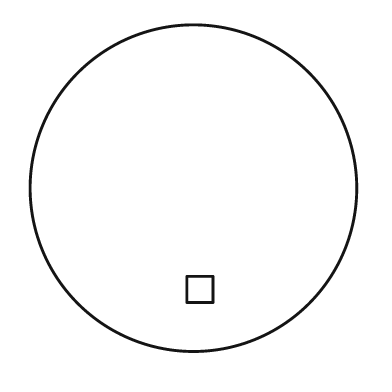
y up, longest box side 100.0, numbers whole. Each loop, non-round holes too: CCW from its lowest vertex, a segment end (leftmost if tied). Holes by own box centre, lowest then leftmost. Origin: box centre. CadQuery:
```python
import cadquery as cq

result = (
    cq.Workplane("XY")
    .moveTo(0.0, 0.0)
    .circle(50.0)
    .moveTo(-2.0, -35.0)
    .lineTo(6.0, -35.0)
    .lineTo(6.0, -27.0)
    .lineTo(-2.0, -27.0)
    .close()
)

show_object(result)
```